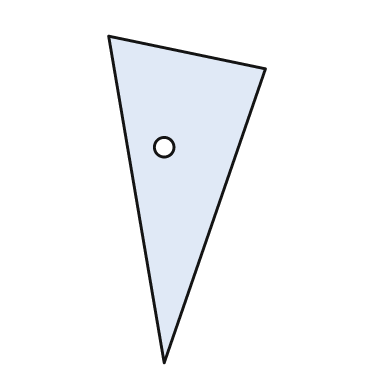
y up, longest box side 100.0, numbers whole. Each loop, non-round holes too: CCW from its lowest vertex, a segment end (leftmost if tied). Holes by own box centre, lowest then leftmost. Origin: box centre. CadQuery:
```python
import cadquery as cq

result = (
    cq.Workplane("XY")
    .moveTo(-7.0, -50.0)
    .lineTo(24.0, 40.0)
    .lineTo(-24.0, 50.0)
    .close()
    .moveTo(-7.0, 16.0)
    .circle(3.0)
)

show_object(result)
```